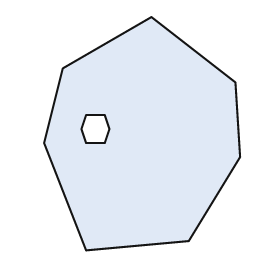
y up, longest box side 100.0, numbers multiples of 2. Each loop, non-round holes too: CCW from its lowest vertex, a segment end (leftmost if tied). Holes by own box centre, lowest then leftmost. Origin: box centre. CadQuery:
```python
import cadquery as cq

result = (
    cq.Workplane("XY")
    .moveTo(-24.0, -50.0)
    .lineTo(20.0, -46.0)
    .lineTo(42.0, -10.0)
    .lineTo(40.0, 22.0)
    .lineTo(4.0, 50.0)
    .lineTo(-34.0, 28.0)
    .lineTo(-42.0, -4.0)
    .close()
    .moveTo(-24.0, -4.0)
    .lineTo(-16.0, -4.0)
    .lineTo(-14.0, 2.0)
    .lineTo(-16.0, 8.0)
    .lineTo(-24.0, 8.0)
    .lineTo(-26.0, 2.0)
    .close()
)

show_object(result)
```